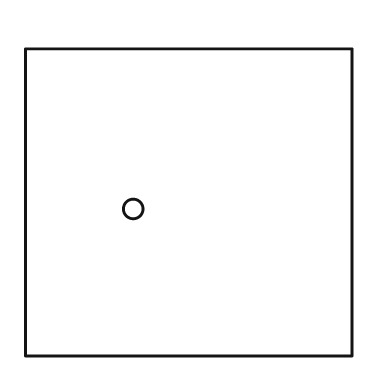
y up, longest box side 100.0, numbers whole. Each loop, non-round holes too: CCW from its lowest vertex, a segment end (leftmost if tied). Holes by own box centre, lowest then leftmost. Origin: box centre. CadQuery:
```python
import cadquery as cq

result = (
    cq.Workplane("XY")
    .moveTo(-50.0, -47.0)
    .lineTo(50.0, -47.0)
    .lineTo(50.0, 47.0)
    .lineTo(-50.0, 47.0)
    .close()
    .moveTo(-17.0, -2.0)
    .circle(3.0)
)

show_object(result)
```